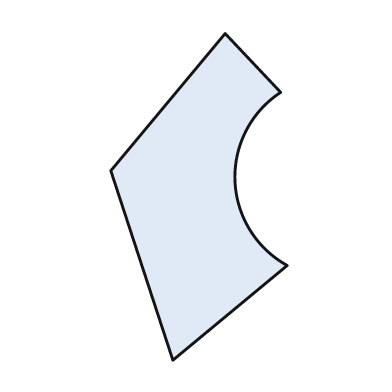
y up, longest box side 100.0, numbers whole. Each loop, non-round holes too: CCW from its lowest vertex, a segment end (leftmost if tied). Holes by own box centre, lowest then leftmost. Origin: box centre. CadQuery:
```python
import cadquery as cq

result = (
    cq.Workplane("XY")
    .moveTo(-8.0, -50.0)
    .lineTo(27.0, -21.0)
    .threePointArc((11.0, 5.0), (25.0, 32.0))
    .lineTo(8.0, 50.0)
    .lineTo(-27.0, 8.0)
    .close()
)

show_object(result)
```